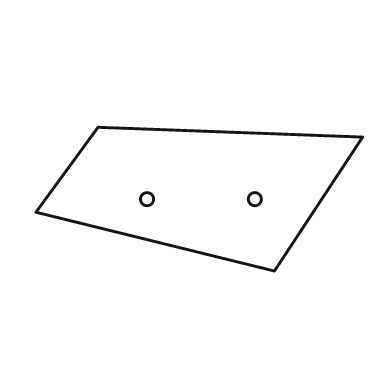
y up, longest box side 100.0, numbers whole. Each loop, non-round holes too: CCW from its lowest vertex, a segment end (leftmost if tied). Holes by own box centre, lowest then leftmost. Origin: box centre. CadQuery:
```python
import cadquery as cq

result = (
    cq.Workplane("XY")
    .moveTo(23.0, -22.0)
    .lineTo(50.0, 19.0)
    .lineTo(-31.0, 22.0)
    .lineTo(-50.0, -4.0)
    .close()
    .moveTo(-16.0, 0.0)
    .circle(2.0)
    .moveTo(17.0, 0.0)
    .circle(2.0)
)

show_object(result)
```